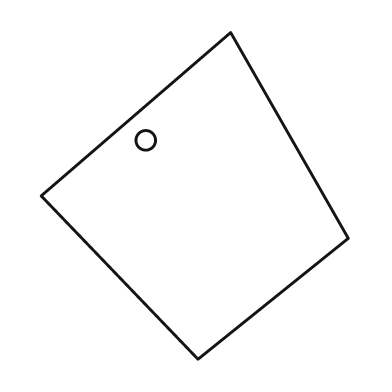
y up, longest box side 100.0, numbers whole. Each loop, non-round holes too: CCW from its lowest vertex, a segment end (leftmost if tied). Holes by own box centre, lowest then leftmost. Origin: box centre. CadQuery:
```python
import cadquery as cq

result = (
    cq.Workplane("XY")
    .moveTo(1.0, -50.0)
    .lineTo(47.0, -13.0)
    .lineTo(11.0, 50.0)
    .lineTo(-47.0, 0.0)
    .close()
    .moveTo(-15.0, 17.0)
    .circle(3.0)
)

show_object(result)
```